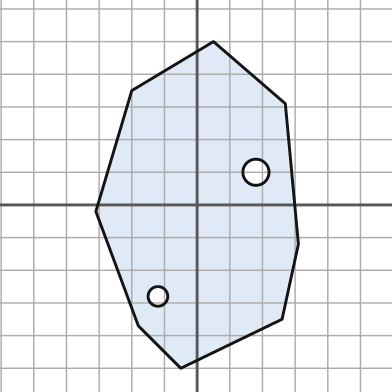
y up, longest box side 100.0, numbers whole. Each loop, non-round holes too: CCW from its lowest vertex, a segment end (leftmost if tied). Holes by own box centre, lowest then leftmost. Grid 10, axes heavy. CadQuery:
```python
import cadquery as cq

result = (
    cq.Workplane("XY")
    .moveTo(-5.0, -50.0)
    .lineTo(26.0, -35.0)
    .lineTo(31.0, -12.0)
    .lineTo(27.0, 31.0)
    .lineTo(5.0, 50.0)
    .lineTo(-20.0, 35.0)
    .lineTo(-31.0, -2.0)
    .lineTo(-18.0, -37.0)
    .close()
    .moveTo(-12.0, -28.0)
    .circle(3.0)
    .moveTo(18.0, 10.0)
    .circle(4.0)
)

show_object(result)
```